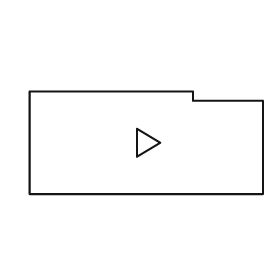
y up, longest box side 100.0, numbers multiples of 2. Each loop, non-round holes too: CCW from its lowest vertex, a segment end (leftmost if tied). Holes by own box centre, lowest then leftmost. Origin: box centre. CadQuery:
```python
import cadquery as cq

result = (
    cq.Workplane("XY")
    .moveTo(-50.0, -22.0)
    .lineTo(50.0, -22.0)
    .lineTo(50.0, 18.0)
    .lineTo(20.0, 18.0)
    .lineTo(20.0, 22.0)
    .lineTo(-50.0, 22.0)
    .close()
    .moveTo(-4.0, -6.0)
    .lineTo(6.0, 0.0)
    .lineTo(-4.0, 6.0)
    .close()
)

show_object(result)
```